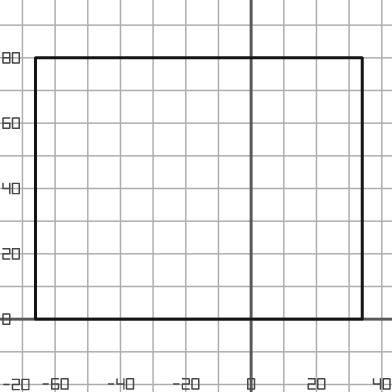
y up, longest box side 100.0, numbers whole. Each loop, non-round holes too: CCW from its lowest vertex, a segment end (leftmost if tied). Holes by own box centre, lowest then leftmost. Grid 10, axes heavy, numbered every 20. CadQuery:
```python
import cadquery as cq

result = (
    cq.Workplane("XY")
    .moveTo(-66.0, 0.0)
    .lineTo(34.0, 0.0)
    .lineTo(34.0, 80.0)
    .lineTo(-66.0, 80.0)
    .close()
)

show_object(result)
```